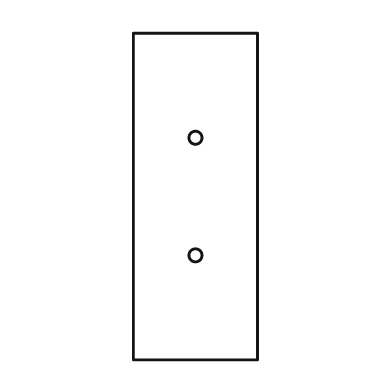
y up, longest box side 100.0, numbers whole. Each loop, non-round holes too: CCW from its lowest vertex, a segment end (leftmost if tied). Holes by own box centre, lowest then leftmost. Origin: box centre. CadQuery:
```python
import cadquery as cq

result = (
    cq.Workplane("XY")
    .moveTo(-19.0, -50.0)
    .lineTo(19.0, -50.0)
    .lineTo(19.0, 50.0)
    .lineTo(-19.0, 50.0)
    .close()
    .moveTo(0.0, -18.0)
    .circle(2.0)
    .moveTo(0.0, 18.0)
    .circle(2.0)
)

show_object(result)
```